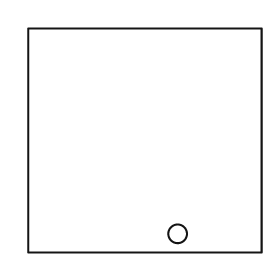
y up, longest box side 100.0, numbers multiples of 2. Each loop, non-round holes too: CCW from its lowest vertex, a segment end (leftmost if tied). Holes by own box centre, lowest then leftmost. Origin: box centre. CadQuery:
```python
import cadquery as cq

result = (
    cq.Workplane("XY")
    .moveTo(-50.0, -48.0)
    .lineTo(50.0, -48.0)
    .lineTo(50.0, 48.0)
    .lineTo(-50.0, 48.0)
    .close()
    .moveTo(14.0, -40.0)
    .circle(4.0)
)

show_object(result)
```